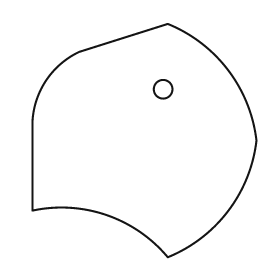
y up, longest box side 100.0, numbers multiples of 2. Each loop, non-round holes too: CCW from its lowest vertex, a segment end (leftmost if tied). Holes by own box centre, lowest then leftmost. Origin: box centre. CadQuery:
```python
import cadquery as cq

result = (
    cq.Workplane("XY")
    .moveTo(10.0, -50.0)
    .threePointArc((36.0, -30.0), (48.0, 0.0))
    .threePointArc((36.0, 30.0), (10.0, 50.0))
    .lineTo(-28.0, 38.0)
    .threePointArc((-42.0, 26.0), (-48.0, 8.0))
    .lineTo(-48.0, -30.0)
    .threePointArc((-16.0, -32.0), (10.0, -50.0))
    .close()
    .moveTo(8.0, 22.0)
    .circle(4.0)
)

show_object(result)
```